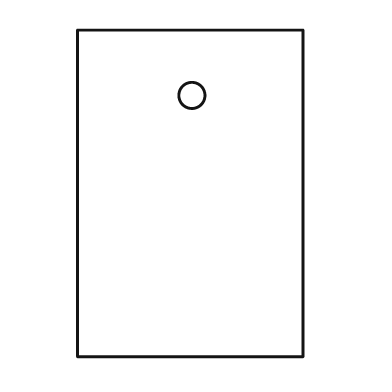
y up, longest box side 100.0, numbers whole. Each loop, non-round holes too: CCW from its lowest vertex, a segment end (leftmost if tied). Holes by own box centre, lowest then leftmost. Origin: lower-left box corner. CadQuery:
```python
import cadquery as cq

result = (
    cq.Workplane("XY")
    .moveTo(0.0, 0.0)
    .lineTo(69.0, 0.0)
    .lineTo(69.0, 100.0)
    .lineTo(0.0, 100.0)
    .close()
    .moveTo(35.0, 80.0)
    .circle(4.0)
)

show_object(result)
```